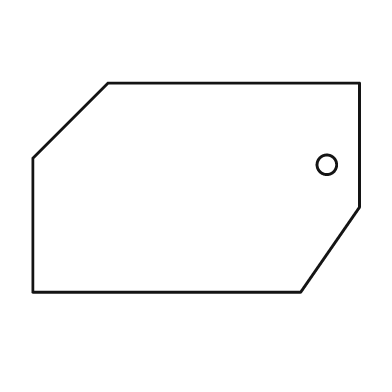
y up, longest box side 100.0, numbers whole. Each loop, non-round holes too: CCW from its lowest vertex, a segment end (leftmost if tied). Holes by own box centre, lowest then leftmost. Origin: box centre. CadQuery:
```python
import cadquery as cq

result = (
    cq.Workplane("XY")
    .moveTo(-50.0, -32.0)
    .lineTo(32.0, -32.0)
    .lineTo(50.0, -6.0)
    .lineTo(50.0, 32.0)
    .lineTo(-27.0, 32.0)
    .lineTo(-50.0, 9.0)
    .close()
    .moveTo(40.0, 7.0)
    .circle(3.0)
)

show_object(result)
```